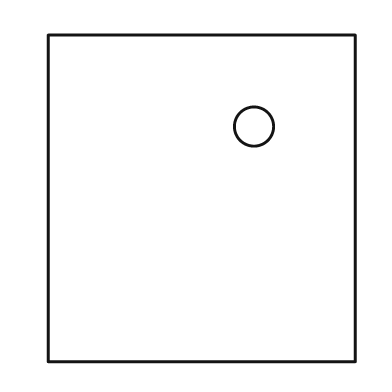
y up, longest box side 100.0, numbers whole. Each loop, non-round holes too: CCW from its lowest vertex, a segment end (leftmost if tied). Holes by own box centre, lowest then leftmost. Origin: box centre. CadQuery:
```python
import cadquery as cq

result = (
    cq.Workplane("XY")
    .moveTo(-47.0, -50.0)
    .lineTo(47.0, -50.0)
    .lineTo(47.0, 50.0)
    .lineTo(-47.0, 50.0)
    .close()
    .moveTo(16.0, 22.0)
    .circle(6.0)
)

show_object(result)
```